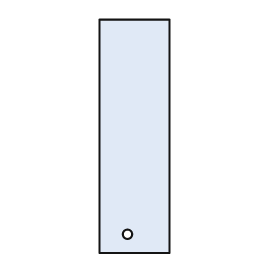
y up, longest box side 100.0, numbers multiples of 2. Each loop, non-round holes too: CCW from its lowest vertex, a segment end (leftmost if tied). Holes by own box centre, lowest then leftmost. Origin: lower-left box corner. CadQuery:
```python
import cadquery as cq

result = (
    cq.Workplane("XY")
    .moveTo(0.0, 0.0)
    .lineTo(30.0, 0.0)
    .lineTo(30.0, 100.0)
    .lineTo(0.0, 100.0)
    .close()
    .moveTo(12.0, 8.0)
    .circle(2.0)
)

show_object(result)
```